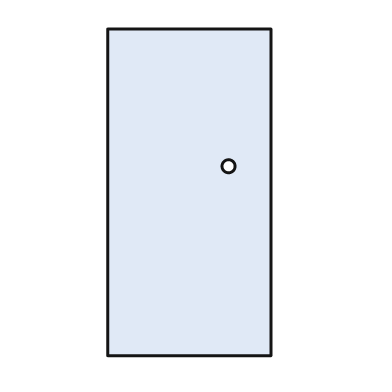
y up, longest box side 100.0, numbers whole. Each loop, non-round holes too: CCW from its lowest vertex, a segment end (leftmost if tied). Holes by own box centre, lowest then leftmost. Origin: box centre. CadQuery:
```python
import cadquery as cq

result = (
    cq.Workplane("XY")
    .moveTo(-25.0, -50.0)
    .lineTo(25.0, -50.0)
    .lineTo(25.0, 50.0)
    .lineTo(-25.0, 50.0)
    .close()
    .moveTo(12.0, 8.0)
    .circle(2.0)
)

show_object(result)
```